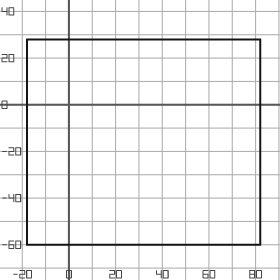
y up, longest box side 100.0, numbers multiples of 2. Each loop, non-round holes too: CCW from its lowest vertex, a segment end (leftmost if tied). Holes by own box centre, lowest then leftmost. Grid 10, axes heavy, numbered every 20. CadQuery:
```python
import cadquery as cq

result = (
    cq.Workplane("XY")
    .moveTo(-18.0, -60.0)
    .lineTo(82.0, -60.0)
    .lineTo(82.0, 28.0)
    .lineTo(-18.0, 28.0)
    .close()
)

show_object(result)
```